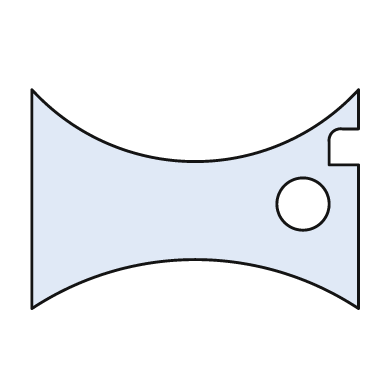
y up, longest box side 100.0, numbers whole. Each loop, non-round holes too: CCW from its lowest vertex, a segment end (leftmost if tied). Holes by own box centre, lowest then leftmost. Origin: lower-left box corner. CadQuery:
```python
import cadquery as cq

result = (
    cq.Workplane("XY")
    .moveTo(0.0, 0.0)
    .threePointArc((50.0, 15.0), (100.0, 0.0))
    .lineTo(100.0, 44.0)
    .lineTo(91.0, 44.0)
    .lineTo(91.0, 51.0)
    .threePointArc((92.0, 54.0), (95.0, 55.0))
    .lineTo(100.0, 55.0)
    .lineTo(100.0, 67.0)
    .threePointArc((50.0, 45.0), (0.0, 67.0))
    .close()
    .moveTo(83.0, 32.0)
    .circle(8.0)
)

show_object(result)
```